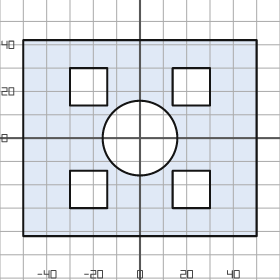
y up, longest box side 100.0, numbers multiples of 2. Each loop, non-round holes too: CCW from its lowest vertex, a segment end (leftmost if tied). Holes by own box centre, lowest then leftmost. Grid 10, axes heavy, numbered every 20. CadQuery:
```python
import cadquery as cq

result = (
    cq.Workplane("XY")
    .moveTo(-50.0, -42.0)
    .lineTo(50.0, -42.0)
    .lineTo(50.0, 42.0)
    .lineTo(-50.0, 42.0)
    .close()
    .moveTo(-30.0, -30.0)
    .lineTo(-14.0, -30.0)
    .lineTo(-14.0, -14.0)
    .lineTo(-30.0, -14.0)
    .close()
    .moveTo(14.0, -30.0)
    .lineTo(30.0, -30.0)
    .lineTo(30.0, -14.0)
    .lineTo(14.0, -14.0)
    .close()
    .moveTo(0.0, 0.0)
    .circle(16.0)
    .moveTo(-30.0, 14.0)
    .lineTo(-14.0, 14.0)
    .lineTo(-14.0, 30.0)
    .lineTo(-30.0, 30.0)
    .close()
    .moveTo(14.0, 14.0)
    .lineTo(30.0, 14.0)
    .lineTo(30.0, 30.0)
    .lineTo(14.0, 30.0)
    .close()
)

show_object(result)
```